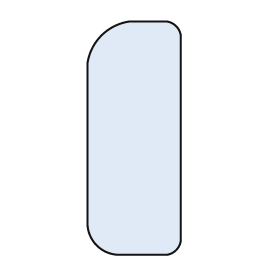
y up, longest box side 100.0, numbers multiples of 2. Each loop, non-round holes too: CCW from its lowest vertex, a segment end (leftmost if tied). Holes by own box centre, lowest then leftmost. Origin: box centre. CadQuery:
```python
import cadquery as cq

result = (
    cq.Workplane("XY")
    .moveTo(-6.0, -50.0)
    .lineTo(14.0, -50.0)
    .threePointArc((18.0, -48.0), (20.0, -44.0))
    .lineTo(20.0, 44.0)
    .threePointArc((18.0, 48.0), (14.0, 50.0))
    .lineTo(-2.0, 50.0)
    .threePointArc((-14.0, 44.0), (-20.0, 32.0))
    .lineTo(-20.0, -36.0)
    .threePointArc((-16.0, -46.0), (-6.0, -50.0))
    .close()
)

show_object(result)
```